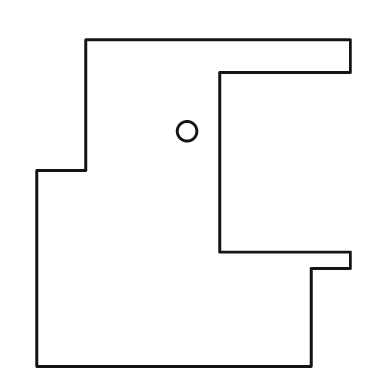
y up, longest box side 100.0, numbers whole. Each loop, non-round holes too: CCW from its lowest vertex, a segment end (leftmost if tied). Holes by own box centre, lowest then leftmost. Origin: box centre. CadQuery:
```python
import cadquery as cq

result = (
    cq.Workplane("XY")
    .moveTo(-48.0, -50.0)
    .lineTo(36.0, -50.0)
    .lineTo(36.0, -20.0)
    .lineTo(48.0, -20.0)
    .lineTo(48.0, -15.0)
    .lineTo(8.0, -15.0)
    .lineTo(8.0, 40.0)
    .lineTo(48.0, 40.0)
    .lineTo(48.0, 50.0)
    .lineTo(-33.0, 50.0)
    .lineTo(-33.0, 10.0)
    .lineTo(-48.0, 10.0)
    .close()
    .moveTo(-2.0, 22.0)
    .circle(3.0)
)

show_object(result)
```